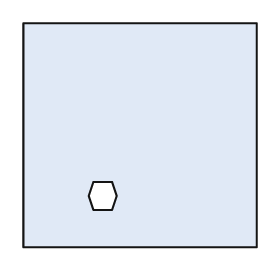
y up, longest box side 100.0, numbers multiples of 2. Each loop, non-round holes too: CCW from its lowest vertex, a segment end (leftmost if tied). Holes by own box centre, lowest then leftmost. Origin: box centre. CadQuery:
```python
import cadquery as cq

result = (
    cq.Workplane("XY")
    .moveTo(-50.0, -48.0)
    .lineTo(50.0, -48.0)
    .lineTo(50.0, 48.0)
    .lineTo(-50.0, 48.0)
    .close()
    .moveTo(-20.0, -32.0)
    .lineTo(-12.0, -32.0)
    .lineTo(-10.0, -26.0)
    .lineTo(-12.0, -20.0)
    .lineTo(-20.0, -20.0)
    .lineTo(-22.0, -26.0)
    .close()
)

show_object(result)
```